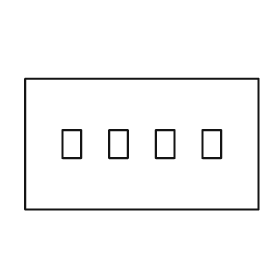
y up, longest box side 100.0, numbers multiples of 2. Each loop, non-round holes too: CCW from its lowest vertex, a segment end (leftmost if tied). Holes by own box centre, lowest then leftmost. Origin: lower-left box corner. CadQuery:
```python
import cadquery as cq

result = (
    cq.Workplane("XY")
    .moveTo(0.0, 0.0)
    .lineTo(100.0, 0.0)
    .lineTo(100.0, 56.0)
    .lineTo(0.0, 56.0)
    .close()
    .moveTo(16.0, 22.0)
    .lineTo(24.0, 22.0)
    .lineTo(24.0, 34.0)
    .lineTo(16.0, 34.0)
    .close()
    .moveTo(36.0, 22.0)
    .lineTo(44.0, 22.0)
    .lineTo(44.0, 34.0)
    .lineTo(36.0, 34.0)
    .close()
    .moveTo(56.0, 22.0)
    .lineTo(64.0, 22.0)
    .lineTo(64.0, 34.0)
    .lineTo(56.0, 34.0)
    .close()
    .moveTo(76.0, 22.0)
    .lineTo(84.0, 22.0)
    .lineTo(84.0, 34.0)
    .lineTo(76.0, 34.0)
    .close()
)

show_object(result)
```